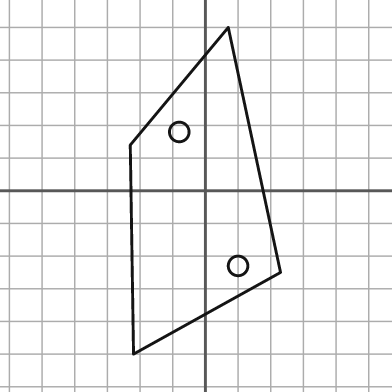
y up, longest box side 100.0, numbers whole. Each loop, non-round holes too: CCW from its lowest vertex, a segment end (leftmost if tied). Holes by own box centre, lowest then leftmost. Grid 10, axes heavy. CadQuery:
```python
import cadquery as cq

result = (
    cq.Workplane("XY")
    .moveTo(-22.0, -50.0)
    .lineTo(23.0, -25.0)
    .lineTo(7.0, 50.0)
    .lineTo(-23.0, 14.0)
    .close()
    .moveTo(10.0, -23.0)
    .circle(3.0)
    .moveTo(-8.0, 18.0)
    .circle(3.0)
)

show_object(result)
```